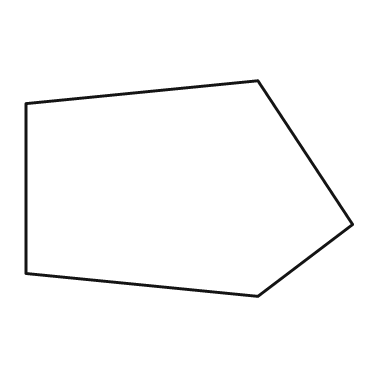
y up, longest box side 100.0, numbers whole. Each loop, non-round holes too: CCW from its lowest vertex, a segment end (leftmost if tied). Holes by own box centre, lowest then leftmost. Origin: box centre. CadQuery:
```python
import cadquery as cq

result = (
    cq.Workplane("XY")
    .moveTo(21.0, -33.0)
    .lineTo(50.0, -11.0)
    .lineTo(21.0, 33.0)
    .lineTo(-50.0, 26.0)
    .lineTo(-50.0, -26.0)
    .close()
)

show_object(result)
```